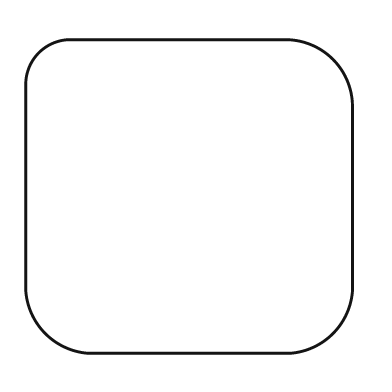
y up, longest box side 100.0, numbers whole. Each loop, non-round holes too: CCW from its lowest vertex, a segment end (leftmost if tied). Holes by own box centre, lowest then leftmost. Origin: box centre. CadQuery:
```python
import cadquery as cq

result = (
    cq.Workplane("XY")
    .moveTo(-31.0, -48.0)
    .lineTo(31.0, -48.0)
    .threePointArc((44.0, -42.0), (50.0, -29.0))
    .lineTo(50.0, 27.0)
    .threePointArc((44.0, 42.0), (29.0, 48.0))
    .lineTo(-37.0, 48.0)
    .threePointArc((-46.0, 44.0), (-50.0, 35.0))
    .lineTo(-50.0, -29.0)
    .threePointArc((-44.0, -42.0), (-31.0, -48.0))
    .close()
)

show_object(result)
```